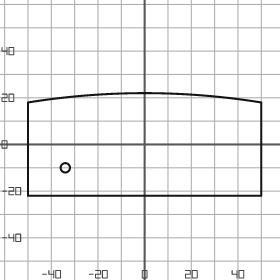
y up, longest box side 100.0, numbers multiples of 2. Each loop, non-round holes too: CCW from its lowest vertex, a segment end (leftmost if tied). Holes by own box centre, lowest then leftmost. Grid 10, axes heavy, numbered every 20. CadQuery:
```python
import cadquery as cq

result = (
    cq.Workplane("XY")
    .moveTo(-50.0, -22.0)
    .lineTo(50.0, -22.0)
    .lineTo(50.0, 18.0)
    .threePointArc((0.0, 22.0), (-50.0, 18.0))
    .close()
    .moveTo(-34.0, -10.0)
    .circle(2.0)
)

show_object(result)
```